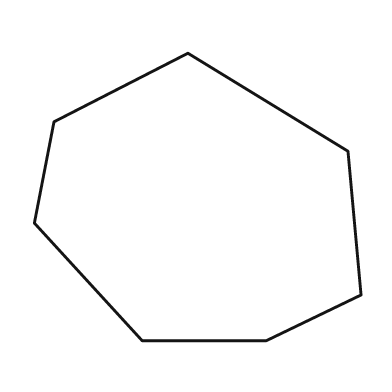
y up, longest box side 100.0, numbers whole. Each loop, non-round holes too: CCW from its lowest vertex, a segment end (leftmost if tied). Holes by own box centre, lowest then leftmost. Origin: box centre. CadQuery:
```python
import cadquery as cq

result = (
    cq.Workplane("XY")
    .moveTo(-17.0, -44.0)
    .lineTo(21.0, -44.0)
    .lineTo(50.0, -30.0)
    .lineTo(46.0, 14.0)
    .lineTo(-3.0, 44.0)
    .lineTo(-44.0, 23.0)
    .lineTo(-50.0, -8.0)
    .close()
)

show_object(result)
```